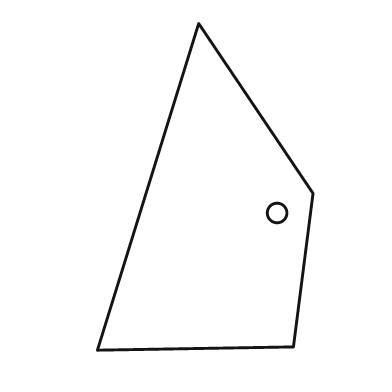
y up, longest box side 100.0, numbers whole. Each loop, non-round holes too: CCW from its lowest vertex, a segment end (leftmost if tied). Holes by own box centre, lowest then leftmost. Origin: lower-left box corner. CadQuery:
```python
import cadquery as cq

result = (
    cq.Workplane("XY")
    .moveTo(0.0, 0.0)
    .lineTo(60.0, 1.0)
    .lineTo(66.0, 48.0)
    .lineTo(31.0, 100.0)
    .close()
    .moveTo(55.0, 42.0)
    .circle(3.0)
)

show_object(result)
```